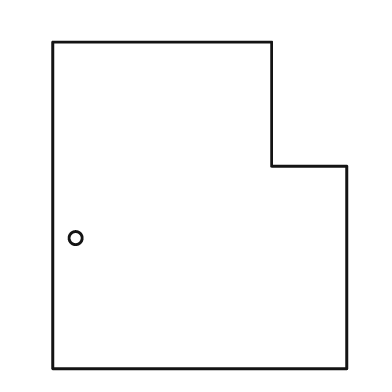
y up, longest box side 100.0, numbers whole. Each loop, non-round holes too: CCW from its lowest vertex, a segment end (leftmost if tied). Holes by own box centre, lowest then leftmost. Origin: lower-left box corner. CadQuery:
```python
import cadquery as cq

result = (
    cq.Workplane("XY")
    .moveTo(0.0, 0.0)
    .lineTo(90.0, 0.0)
    .lineTo(90.0, 62.0)
    .lineTo(67.0, 62.0)
    .lineTo(67.0, 100.0)
    .lineTo(0.0, 100.0)
    .close()
    .moveTo(7.0, 40.0)
    .circle(2.0)
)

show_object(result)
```